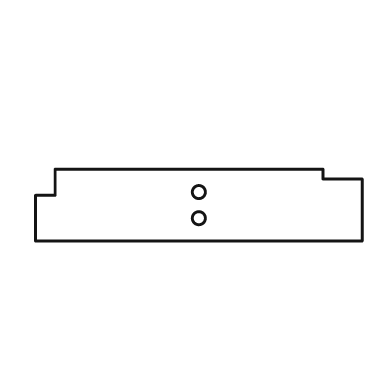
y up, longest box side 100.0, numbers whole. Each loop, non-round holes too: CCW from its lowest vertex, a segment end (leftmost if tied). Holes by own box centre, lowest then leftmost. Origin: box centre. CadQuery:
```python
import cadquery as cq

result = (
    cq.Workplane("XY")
    .moveTo(-50.0, -11.0)
    .lineTo(50.0, -11.0)
    .lineTo(50.0, 8.0)
    .lineTo(38.0, 8.0)
    .lineTo(38.0, 11.0)
    .lineTo(-44.0, 11.0)
    .lineTo(-44.0, 3.0)
    .lineTo(-50.0, 3.0)
    .close()
    .moveTo(0.0, -4.0)
    .circle(2.0)
    .moveTo(0.0, 4.0)
    .circle(2.0)
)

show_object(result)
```